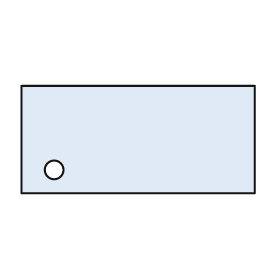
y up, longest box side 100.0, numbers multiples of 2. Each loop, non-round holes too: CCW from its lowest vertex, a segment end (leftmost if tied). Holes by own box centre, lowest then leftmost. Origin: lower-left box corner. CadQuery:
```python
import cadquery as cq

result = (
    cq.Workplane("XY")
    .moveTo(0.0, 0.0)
    .lineTo(100.0, 0.0)
    .lineTo(100.0, 46.0)
    .lineTo(0.0, 46.0)
    .close()
    .moveTo(14.0, 10.0)
    .circle(4.0)
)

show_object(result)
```